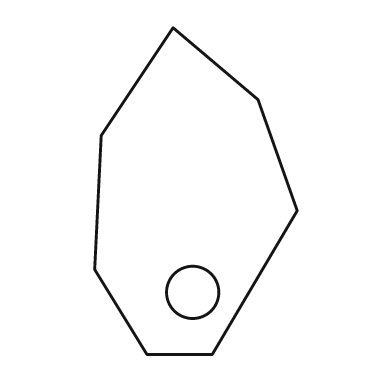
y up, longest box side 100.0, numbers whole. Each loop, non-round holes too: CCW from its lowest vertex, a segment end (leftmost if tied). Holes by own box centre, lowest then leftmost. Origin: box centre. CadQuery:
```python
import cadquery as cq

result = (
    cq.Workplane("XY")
    .moveTo(-15.0, -50.0)
    .lineTo(5.0, -50.0)
    .lineTo(31.0, -6.0)
    .lineTo(19.0, 28.0)
    .lineTo(-7.0, 50.0)
    .lineTo(-29.0, 17.0)
    .lineTo(-31.0, -24.0)
    .close()
    .moveTo(-1.0, -31.0)
    .circle(8.0)
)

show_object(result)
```